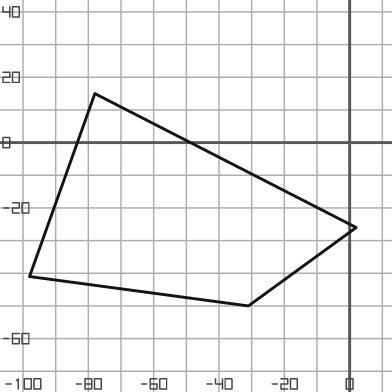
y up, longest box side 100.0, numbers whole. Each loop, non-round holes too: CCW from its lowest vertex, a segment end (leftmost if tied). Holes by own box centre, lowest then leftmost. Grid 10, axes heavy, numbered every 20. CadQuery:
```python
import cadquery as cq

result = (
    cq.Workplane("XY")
    .moveTo(-31.0, -50.0)
    .lineTo(2.0, -26.0)
    .lineTo(-78.0, 15.0)
    .lineTo(-98.0, -41.0)
    .close()
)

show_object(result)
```